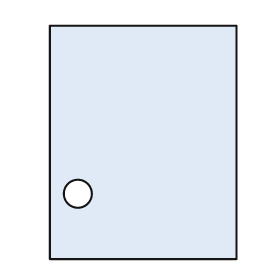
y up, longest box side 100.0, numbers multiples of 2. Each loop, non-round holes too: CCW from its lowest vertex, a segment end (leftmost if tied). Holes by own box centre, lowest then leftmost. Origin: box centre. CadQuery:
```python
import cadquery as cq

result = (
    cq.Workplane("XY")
    .moveTo(-40.0, -50.0)
    .lineTo(40.0, -50.0)
    .lineTo(40.0, 50.0)
    .lineTo(-40.0, 50.0)
    .close()
    .moveTo(-28.0, -22.0)
    .circle(6.0)
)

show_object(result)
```